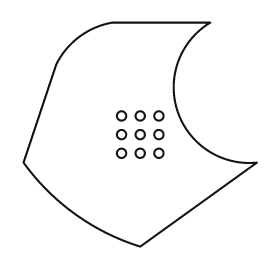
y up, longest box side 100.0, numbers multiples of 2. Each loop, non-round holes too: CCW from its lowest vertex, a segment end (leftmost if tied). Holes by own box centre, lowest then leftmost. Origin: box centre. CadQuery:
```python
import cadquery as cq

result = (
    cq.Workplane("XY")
    .moveTo(0.0, -48.0)
    .lineTo(50.0, -12.0)
    .threePointArc((16.0, 10.0), (30.0, 48.0))
    .lineTo(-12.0, 48.0)
    .threePointArc((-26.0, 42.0), (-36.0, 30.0))
    .lineTo(-50.0, -12.0)
    .threePointArc((-28.0, -34.0), (0.0, -48.0))
    .close()
    .moveTo(-8.0, -8.0)
    .circle(2.0)
    .moveTo(0.0, -8.0)
    .circle(2.0)
    .moveTo(8.0, -8.0)
    .circle(2.0)
    .moveTo(-8.0, 0.0)
    .circle(2.0)
    .moveTo(0.0, 0.0)
    .circle(2.0)
    .moveTo(8.0, 0.0)
    .circle(2.0)
    .moveTo(-8.0, 8.0)
    .circle(2.0)
    .moveTo(0.0, 8.0)
    .circle(2.0)
    .moveTo(8.0, 8.0)
    .circle(2.0)
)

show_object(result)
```